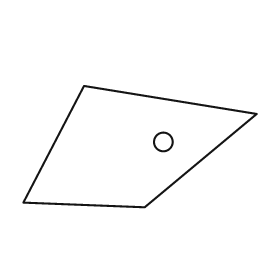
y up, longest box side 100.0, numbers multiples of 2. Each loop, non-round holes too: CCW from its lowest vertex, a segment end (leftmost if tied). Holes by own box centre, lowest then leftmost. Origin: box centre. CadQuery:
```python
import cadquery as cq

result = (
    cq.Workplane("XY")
    .moveTo(2.0, -26.0)
    .lineTo(50.0, 14.0)
    .lineTo(-24.0, 26.0)
    .lineTo(-50.0, -24.0)
    .close()
    .moveTo(10.0, 2.0)
    .circle(4.0)
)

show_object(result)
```